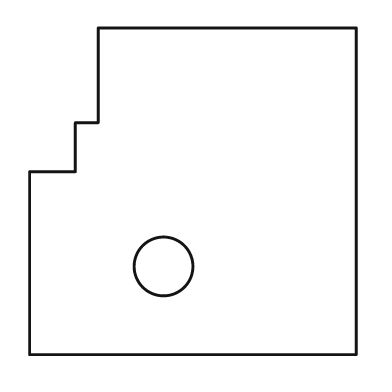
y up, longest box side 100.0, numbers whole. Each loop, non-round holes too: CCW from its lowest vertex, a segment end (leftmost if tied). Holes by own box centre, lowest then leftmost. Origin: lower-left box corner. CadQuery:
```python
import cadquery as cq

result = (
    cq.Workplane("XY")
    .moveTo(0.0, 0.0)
    .lineTo(100.0, 0.0)
    .lineTo(100.0, 100.0)
    .lineTo(21.0, 100.0)
    .lineTo(21.0, 71.0)
    .lineTo(14.0, 71.0)
    .lineTo(14.0, 56.0)
    .lineTo(0.0, 56.0)
    .close()
    .moveTo(41.0, 27.0)
    .circle(9.0)
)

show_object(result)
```